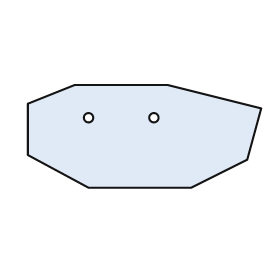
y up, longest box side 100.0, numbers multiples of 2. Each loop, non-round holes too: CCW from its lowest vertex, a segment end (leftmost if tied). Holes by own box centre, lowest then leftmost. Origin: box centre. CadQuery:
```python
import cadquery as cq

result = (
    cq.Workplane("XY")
    .moveTo(-24.0, -22.0)
    .lineTo(20.0, -22.0)
    .lineTo(44.0, -10.0)
    .lineTo(50.0, 12.0)
    .lineTo(10.0, 22.0)
    .lineTo(-30.0, 22.0)
    .lineTo(-50.0, 14.0)
    .lineTo(-50.0, -8.0)
    .close()
    .moveTo(-24.0, 8.0)
    .circle(2.0)
    .moveTo(4.0, 8.0)
    .circle(2.0)
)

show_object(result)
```